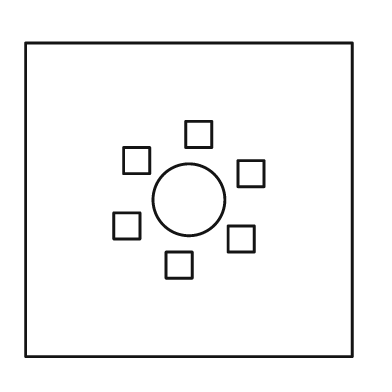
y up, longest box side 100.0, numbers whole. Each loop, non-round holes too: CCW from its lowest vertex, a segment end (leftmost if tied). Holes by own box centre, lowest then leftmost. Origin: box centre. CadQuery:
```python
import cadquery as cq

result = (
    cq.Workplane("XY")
    .moveTo(-50.0, -48.0)
    .lineTo(50.0, -48.0)
    .lineTo(50.0, 48.0)
    .lineTo(-50.0, 48.0)
    .close()
    .moveTo(-7.0, -24.0)
    .lineTo(1.0, -24.0)
    .lineTo(1.0, -16.0)
    .lineTo(-7.0, -16.0)
    .close()
    .moveTo(12.0, -16.0)
    .lineTo(20.0, -16.0)
    .lineTo(20.0, -8.0)
    .lineTo(12.0, -8.0)
    .close()
    .moveTo(-23.0, -12.0)
    .lineTo(-15.0, -12.0)
    .lineTo(-15.0, -4.0)
    .lineTo(-23.0, -4.0)
    .close()
    .moveTo(0.0, 0.0)
    .circle(11.0)
    .moveTo(15.0, 4.0)
    .lineTo(23.0, 4.0)
    .lineTo(23.0, 12.0)
    .lineTo(15.0, 12.0)
    .close()
    .moveTo(-20.0, 8.0)
    .lineTo(-12.0, 8.0)
    .lineTo(-12.0, 16.0)
    .lineTo(-20.0, 16.0)
    .close()
    .moveTo(-1.0, 16.0)
    .lineTo(7.0, 16.0)
    .lineTo(7.0, 24.0)
    .lineTo(-1.0, 24.0)
    .close()
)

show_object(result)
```